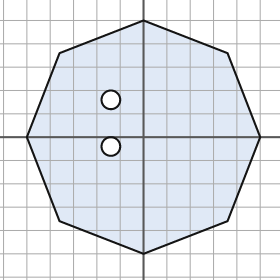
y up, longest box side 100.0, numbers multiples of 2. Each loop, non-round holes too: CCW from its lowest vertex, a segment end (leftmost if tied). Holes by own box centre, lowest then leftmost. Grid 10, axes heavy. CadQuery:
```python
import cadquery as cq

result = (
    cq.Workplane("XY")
    .moveTo(0.0, -50.0)
    .lineTo(36.0, -36.0)
    .lineTo(50.0, 0.0)
    .lineTo(36.0, 36.0)
    .lineTo(0.0, 50.0)
    .lineTo(-36.0, 36.0)
    .lineTo(-50.0, 0.0)
    .lineTo(-36.0, -36.0)
    .close()
    .moveTo(-14.0, -4.0)
    .circle(4.0)
    .moveTo(-14.0, 16.0)
    .circle(4.0)
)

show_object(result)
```